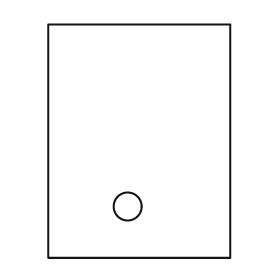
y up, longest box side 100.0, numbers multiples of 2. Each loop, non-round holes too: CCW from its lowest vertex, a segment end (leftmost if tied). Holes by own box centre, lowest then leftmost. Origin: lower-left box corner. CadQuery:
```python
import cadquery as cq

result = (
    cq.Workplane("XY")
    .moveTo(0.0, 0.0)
    .lineTo(78.0, 0.0)
    .lineTo(78.0, 100.0)
    .lineTo(0.0, 100.0)
    .close()
    .moveTo(34.0, 22.0)
    .circle(6.0)
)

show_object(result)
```